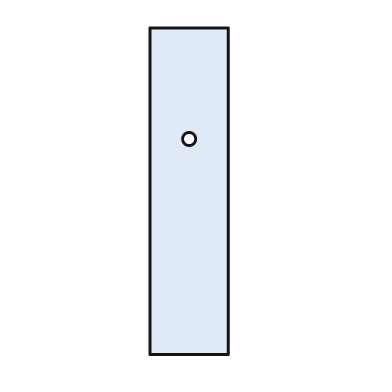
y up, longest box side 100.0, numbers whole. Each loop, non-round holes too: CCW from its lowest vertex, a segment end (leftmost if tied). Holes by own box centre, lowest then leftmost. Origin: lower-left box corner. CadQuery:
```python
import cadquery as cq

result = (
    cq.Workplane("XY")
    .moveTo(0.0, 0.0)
    .lineTo(24.0, 0.0)
    .lineTo(24.0, 100.0)
    .lineTo(0.0, 100.0)
    .close()
    .moveTo(12.0, 66.0)
    .circle(2.0)
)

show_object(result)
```